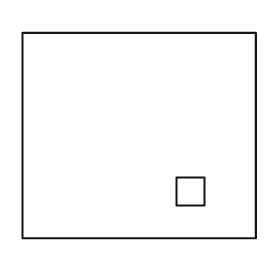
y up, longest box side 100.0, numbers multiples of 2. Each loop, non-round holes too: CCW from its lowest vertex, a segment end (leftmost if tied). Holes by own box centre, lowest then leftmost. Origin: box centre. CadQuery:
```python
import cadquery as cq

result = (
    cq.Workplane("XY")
    .moveTo(-50.0, -44.0)
    .lineTo(50.0, -44.0)
    .lineTo(50.0, 44.0)
    .lineTo(-50.0, 44.0)
    .close()
    .moveTo(16.0, -30.0)
    .lineTo(28.0, -30.0)
    .lineTo(28.0, -18.0)
    .lineTo(16.0, -18.0)
    .close()
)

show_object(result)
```